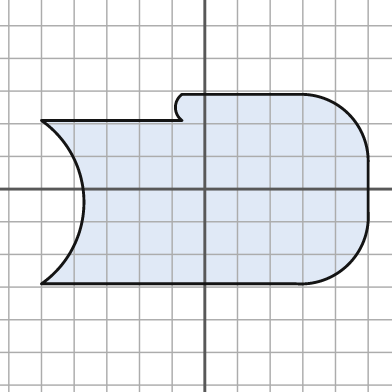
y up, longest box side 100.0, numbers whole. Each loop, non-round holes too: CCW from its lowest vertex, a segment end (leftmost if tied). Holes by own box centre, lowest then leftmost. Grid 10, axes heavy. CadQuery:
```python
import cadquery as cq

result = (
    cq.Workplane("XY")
    .moveTo(-50.0, -29.0)
    .lineTo(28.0, -29.0)
    .threePointArc((44.0, -23.0), (50.0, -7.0))
    .lineTo(50.0, 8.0)
    .threePointArc((44.0, 23.0), (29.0, 29.0))
    .lineTo(-7.0, 29.0)
    .threePointArc((-9.0, 25.0), (-7.0, 21.0))
    .lineTo(-50.0, 21.0)
    .threePointArc((-37.0, -4.0), (-50.0, -29.0))
    .close()
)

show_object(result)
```